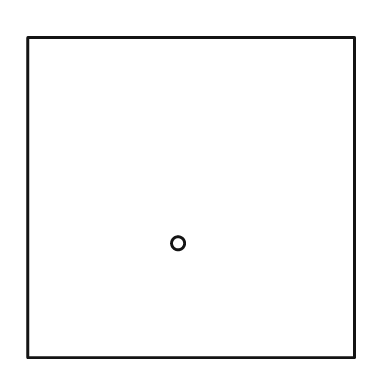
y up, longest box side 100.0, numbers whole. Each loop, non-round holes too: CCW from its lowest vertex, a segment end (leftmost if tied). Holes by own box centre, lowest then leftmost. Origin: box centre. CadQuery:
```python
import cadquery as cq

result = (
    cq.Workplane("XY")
    .moveTo(-50.0, -49.0)
    .lineTo(50.0, -49.0)
    .lineTo(50.0, 49.0)
    .lineTo(-50.0, 49.0)
    .close()
    .moveTo(-4.0, -14.0)
    .circle(2.0)
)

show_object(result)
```